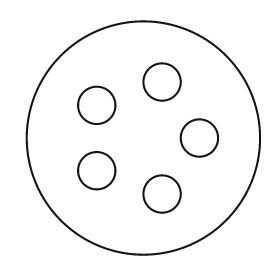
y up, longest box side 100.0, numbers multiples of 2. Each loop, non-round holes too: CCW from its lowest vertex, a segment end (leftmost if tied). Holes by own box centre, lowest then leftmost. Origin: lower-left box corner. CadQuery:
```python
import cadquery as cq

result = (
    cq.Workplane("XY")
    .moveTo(50.0, 50.0)
    .circle(50.0)
    .moveTo(58.0, 26.0)
    .circle(8.0)
    .moveTo(30.0, 36.0)
    .circle(8.0)
    .moveTo(74.0, 50.0)
    .circle(8.0)
    .moveTo(30.0, 64.0)
    .circle(8.0)
    .moveTo(58.0, 74.0)
    .circle(8.0)
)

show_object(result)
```